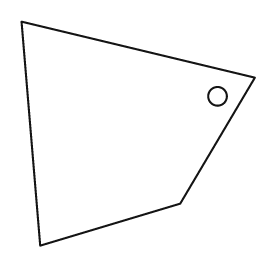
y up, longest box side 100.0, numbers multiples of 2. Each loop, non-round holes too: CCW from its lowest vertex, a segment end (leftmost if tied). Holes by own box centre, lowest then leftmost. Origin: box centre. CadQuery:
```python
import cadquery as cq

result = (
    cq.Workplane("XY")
    .moveTo(-42.0, -48.0)
    .lineTo(18.0, -30.0)
    .lineTo(50.0, 24.0)
    .lineTo(-50.0, 48.0)
    .close()
    .moveTo(34.0, 16.0)
    .circle(4.0)
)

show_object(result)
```